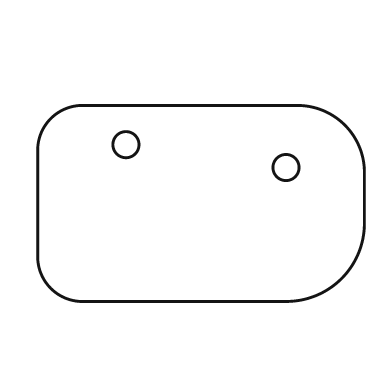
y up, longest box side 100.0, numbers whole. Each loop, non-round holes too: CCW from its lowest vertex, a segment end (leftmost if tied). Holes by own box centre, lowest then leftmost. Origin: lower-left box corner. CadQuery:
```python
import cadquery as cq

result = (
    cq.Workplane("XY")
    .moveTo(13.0, 0.0)
    .lineTo(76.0, 0.0)
    .threePointArc((93.0, 7.0), (100.0, 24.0))
    .lineTo(100.0, 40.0)
    .threePointArc((94.0, 54.0), (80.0, 60.0))
    .lineTo(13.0, 60.0)
    .threePointArc((4.0, 56.0), (0.0, 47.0))
    .lineTo(0.0, 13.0)
    .threePointArc((4.0, 4.0), (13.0, 0.0))
    .close()
    .moveTo(76.0, 41.0)
    .circle(4.0)
    .moveTo(27.0, 48.0)
    .circle(4.0)
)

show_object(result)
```